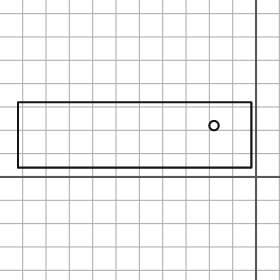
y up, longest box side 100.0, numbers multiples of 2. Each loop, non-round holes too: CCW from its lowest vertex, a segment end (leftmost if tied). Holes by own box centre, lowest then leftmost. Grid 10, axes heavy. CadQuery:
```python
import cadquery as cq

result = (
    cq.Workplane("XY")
    .moveTo(-102.0, 4.0)
    .lineTo(-2.0, 4.0)
    .lineTo(-2.0, 32.0)
    .lineTo(-102.0, 32.0)
    .close()
    .moveTo(-18.0, 22.0)
    .circle(2.0)
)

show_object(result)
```